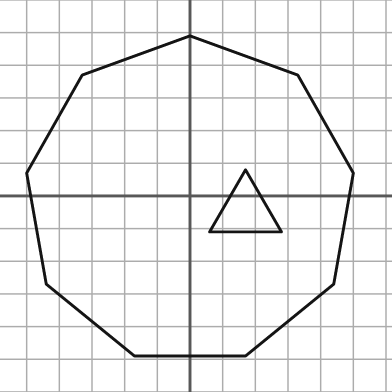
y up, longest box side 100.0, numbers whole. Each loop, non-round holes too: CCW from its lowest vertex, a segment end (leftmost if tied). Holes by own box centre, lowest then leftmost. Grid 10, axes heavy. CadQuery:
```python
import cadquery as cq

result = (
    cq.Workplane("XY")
    .moveTo(-17.0, -49.0)
    .lineTo(17.0, -49.0)
    .lineTo(44.0, -27.0)
    .lineTo(50.0, 7.0)
    .lineTo(33.0, 37.0)
    .lineTo(0.0, 49.0)
    .lineTo(-33.0, 37.0)
    .lineTo(-50.0, 7.0)
    .lineTo(-44.0, -27.0)
    .close()
    .moveTo(6.0, -11.0)
    .lineTo(28.0, -11.0)
    .lineTo(17.0, 8.0)
    .close()
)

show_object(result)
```